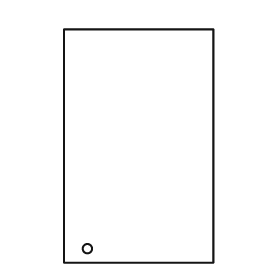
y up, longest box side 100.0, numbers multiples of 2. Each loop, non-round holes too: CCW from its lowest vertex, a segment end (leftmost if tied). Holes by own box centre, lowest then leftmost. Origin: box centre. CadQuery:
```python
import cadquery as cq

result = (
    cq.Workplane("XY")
    .moveTo(-32.0, -50.0)
    .lineTo(32.0, -50.0)
    .lineTo(32.0, 50.0)
    .lineTo(-32.0, 50.0)
    .close()
    .moveTo(-22.0, -44.0)
    .circle(2.0)
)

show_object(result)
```